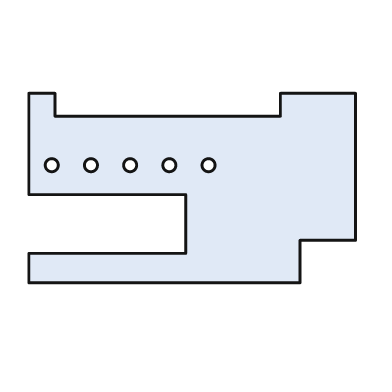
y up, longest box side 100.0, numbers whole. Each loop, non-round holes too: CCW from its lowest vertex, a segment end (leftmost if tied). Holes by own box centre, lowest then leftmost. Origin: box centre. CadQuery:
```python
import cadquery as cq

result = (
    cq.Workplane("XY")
    .moveTo(-50.0, -29.0)
    .lineTo(33.0, -29.0)
    .lineTo(33.0, -16.0)
    .lineTo(50.0, -16.0)
    .lineTo(50.0, 29.0)
    .lineTo(27.0, 29.0)
    .lineTo(27.0, 22.0)
    .lineTo(-42.0, 22.0)
    .lineTo(-42.0, 29.0)
    .lineTo(-50.0, 29.0)
    .lineTo(-50.0, -2.0)
    .lineTo(-2.0, -2.0)
    .lineTo(-2.0, -20.0)
    .lineTo(-50.0, -20.0)
    .close()
    .moveTo(-43.0, 7.0)
    .circle(2.0)
    .moveTo(-31.0, 7.0)
    .circle(2.0)
    .moveTo(-19.0, 7.0)
    .circle(2.0)
    .moveTo(-7.0, 7.0)
    .circle(2.0)
    .moveTo(5.0, 7.0)
    .circle(2.0)
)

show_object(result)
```